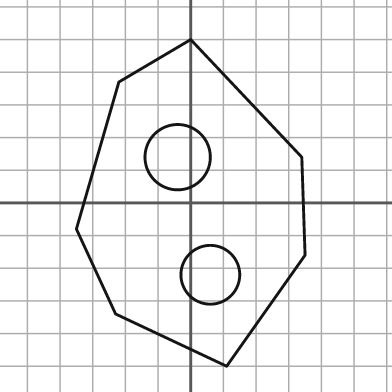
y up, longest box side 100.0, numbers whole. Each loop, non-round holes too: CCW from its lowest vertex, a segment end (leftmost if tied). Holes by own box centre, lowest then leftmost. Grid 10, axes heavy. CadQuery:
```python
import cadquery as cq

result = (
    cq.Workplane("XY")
    .moveTo(11.0, -50.0)
    .lineTo(35.0, -16.0)
    .lineTo(34.0, 14.0)
    .lineTo(0.0, 50.0)
    .lineTo(-22.0, 37.0)
    .lineTo(-35.0, -8.0)
    .lineTo(-23.0, -34.0)
    .close()
    .moveTo(6.0, -22.0)
    .circle(9.0)
    .moveTo(-4.0, 14.0)
    .circle(10.0)
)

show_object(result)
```